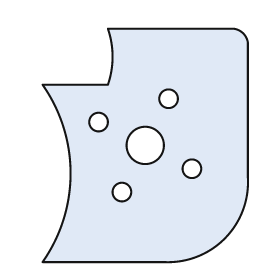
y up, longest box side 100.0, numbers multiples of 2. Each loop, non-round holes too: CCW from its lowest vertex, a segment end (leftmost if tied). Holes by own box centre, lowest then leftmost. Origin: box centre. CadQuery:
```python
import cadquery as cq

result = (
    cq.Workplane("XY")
    .moveTo(-44.0, -50.0)
    .lineTo(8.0, -50.0)
    .threePointArc((34.0, -40.0), (44.0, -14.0))
    .lineTo(44.0, 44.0)
    .threePointArc((42.0, 48.0), (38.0, 50.0))
    .lineTo(-16.0, 50.0)
    .threePointArc((-14.0, 38.0), (-16.0, 26.0))
    .lineTo(-44.0, 26.0)
    .threePointArc((-32.0, -12.0), (-44.0, -50.0))
    .close()
    .moveTo(-10.0, -20.0)
    .circle(4.0)
    .moveTo(20.0, -10.0)
    .circle(4.0)
    .moveTo(0.0, 0.0)
    .circle(8.0)
    .moveTo(-20.0, 10.0)
    .circle(4.0)
    .moveTo(10.0, 20.0)
    .circle(4.0)
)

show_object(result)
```